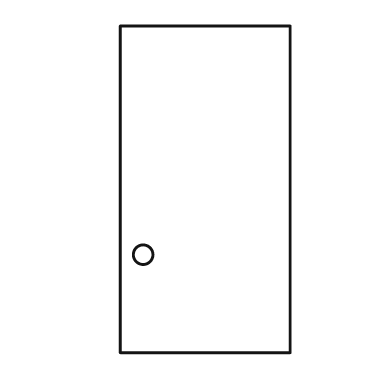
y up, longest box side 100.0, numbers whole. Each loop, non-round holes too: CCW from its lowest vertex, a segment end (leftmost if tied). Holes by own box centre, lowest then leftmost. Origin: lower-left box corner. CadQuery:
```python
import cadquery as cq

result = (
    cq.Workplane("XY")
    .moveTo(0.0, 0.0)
    .lineTo(52.0, 0.0)
    .lineTo(52.0, 100.0)
    .lineTo(0.0, 100.0)
    .close()
    .moveTo(7.0, 30.0)
    .circle(3.0)
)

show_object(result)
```